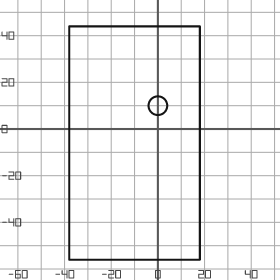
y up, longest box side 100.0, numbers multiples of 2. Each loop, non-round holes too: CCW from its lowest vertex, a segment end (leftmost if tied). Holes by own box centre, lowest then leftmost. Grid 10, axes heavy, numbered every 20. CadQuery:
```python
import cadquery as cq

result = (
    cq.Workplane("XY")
    .moveTo(-38.0, -56.0)
    .lineTo(18.0, -56.0)
    .lineTo(18.0, 44.0)
    .lineTo(-38.0, 44.0)
    .close()
    .moveTo(0.0, 10.0)
    .circle(4.0)
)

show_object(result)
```